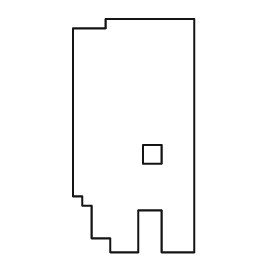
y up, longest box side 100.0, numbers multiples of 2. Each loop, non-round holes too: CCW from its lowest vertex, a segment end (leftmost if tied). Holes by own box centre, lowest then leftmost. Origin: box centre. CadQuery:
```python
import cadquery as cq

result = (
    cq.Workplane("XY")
    .moveTo(-10.0, -50.0)
    .lineTo(2.0, -50.0)
    .lineTo(2.0, -32.0)
    .lineTo(12.0, -32.0)
    .lineTo(12.0, -50.0)
    .lineTo(26.0, -50.0)
    .lineTo(26.0, 50.0)
    .lineTo(-12.0, 50.0)
    .lineTo(-12.0, 46.0)
    .lineTo(-26.0, 46.0)
    .lineTo(-26.0, -26.0)
    .lineTo(-22.0, -26.0)
    .lineTo(-22.0, -30.0)
    .lineTo(-18.0, -30.0)
    .lineTo(-18.0, -44.0)
    .lineTo(-10.0, -44.0)
    .close()
    .moveTo(4.0, -12.0)
    .lineTo(12.0, -12.0)
    .lineTo(12.0, -4.0)
    .lineTo(4.0, -4.0)
    .close()
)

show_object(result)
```